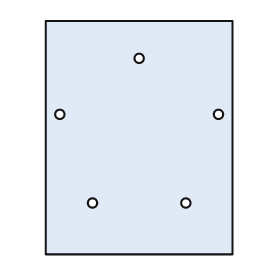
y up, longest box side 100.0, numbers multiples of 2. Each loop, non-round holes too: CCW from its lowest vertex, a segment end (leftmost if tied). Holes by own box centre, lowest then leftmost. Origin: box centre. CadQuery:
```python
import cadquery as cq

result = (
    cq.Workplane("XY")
    .moveTo(-40.0, -50.0)
    .lineTo(40.0, -50.0)
    .lineTo(40.0, 50.0)
    .lineTo(-40.0, 50.0)
    .close()
    .moveTo(-20.0, -28.0)
    .circle(2.0)
    .moveTo(20.0, -28.0)
    .circle(2.0)
    .moveTo(-34.0, 10.0)
    .circle(2.0)
    .moveTo(34.0, 10.0)
    .circle(2.0)
    .moveTo(0.0, 34.0)
    .circle(2.0)
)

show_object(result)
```